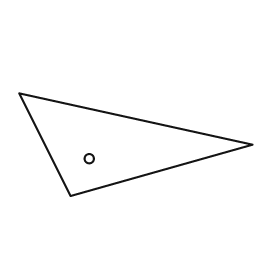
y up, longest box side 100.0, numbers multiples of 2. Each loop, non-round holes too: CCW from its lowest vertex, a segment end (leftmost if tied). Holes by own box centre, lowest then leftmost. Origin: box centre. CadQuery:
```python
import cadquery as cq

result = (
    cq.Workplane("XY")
    .moveTo(-28.0, -22.0)
    .lineTo(50.0, 0.0)
    .lineTo(-50.0, 22.0)
    .close()
    .moveTo(-20.0, -6.0)
    .circle(2.0)
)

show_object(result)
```